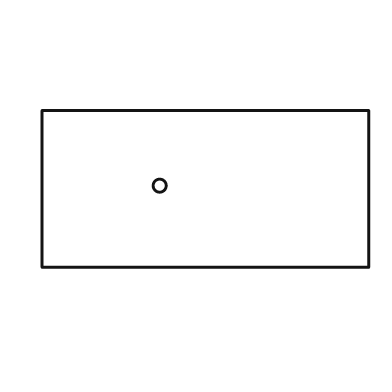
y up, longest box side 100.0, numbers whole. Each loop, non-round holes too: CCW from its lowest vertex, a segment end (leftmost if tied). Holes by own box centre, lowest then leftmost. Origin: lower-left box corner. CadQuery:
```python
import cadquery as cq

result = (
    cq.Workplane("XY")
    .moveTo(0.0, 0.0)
    .lineTo(100.0, 0.0)
    .lineTo(100.0, 48.0)
    .lineTo(0.0, 48.0)
    .close()
    .moveTo(36.0, 25.0)
    .circle(2.0)
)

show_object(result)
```